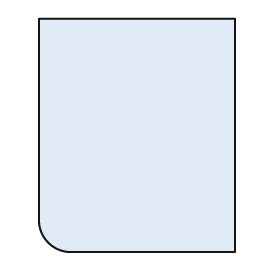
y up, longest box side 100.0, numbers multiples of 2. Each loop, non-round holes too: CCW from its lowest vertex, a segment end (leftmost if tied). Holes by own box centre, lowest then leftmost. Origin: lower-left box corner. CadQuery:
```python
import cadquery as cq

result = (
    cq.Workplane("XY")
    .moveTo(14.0, 0.0)
    .lineTo(84.0, 0.0)
    .lineTo(84.0, 100.0)
    .lineTo(0.0, 100.0)
    .lineTo(0.0, 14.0)
    .threePointArc((4.0, 4.0), (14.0, 0.0))
    .close()
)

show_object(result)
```